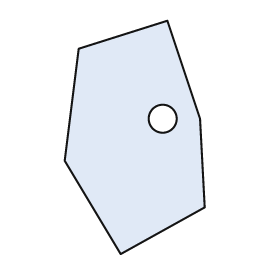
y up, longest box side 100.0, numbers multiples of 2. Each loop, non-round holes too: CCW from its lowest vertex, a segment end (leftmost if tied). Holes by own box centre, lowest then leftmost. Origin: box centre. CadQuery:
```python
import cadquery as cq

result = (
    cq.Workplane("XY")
    .moveTo(-6.0, -50.0)
    .lineTo(30.0, -30.0)
    .lineTo(28.0, 8.0)
    .lineTo(14.0, 50.0)
    .lineTo(-24.0, 38.0)
    .lineTo(-30.0, -10.0)
    .close()
    .moveTo(12.0, 8.0)
    .circle(6.0)
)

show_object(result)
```